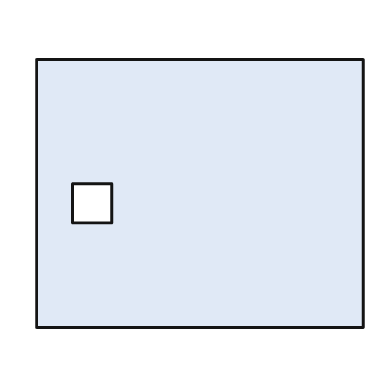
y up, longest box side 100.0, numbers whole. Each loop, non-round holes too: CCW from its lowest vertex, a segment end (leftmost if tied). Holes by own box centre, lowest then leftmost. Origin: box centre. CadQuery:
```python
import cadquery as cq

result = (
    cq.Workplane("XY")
    .moveTo(-50.0, -41.0)
    .lineTo(50.0, -41.0)
    .lineTo(50.0, 41.0)
    .lineTo(-50.0, 41.0)
    .close()
    .moveTo(-39.0, -9.0)
    .lineTo(-27.0, -9.0)
    .lineTo(-27.0, 3.0)
    .lineTo(-39.0, 3.0)
    .close()
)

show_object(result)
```